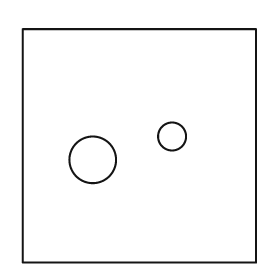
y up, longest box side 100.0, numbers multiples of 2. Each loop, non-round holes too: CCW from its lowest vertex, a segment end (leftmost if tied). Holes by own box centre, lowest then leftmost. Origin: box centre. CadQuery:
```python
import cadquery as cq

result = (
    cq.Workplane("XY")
    .moveTo(-50.0, -50.0)
    .lineTo(50.0, -50.0)
    .lineTo(50.0, 50.0)
    .lineTo(-50.0, 50.0)
    .close()
    .moveTo(-20.0, -6.0)
    .circle(10.0)
    .moveTo(14.0, 4.0)
    .circle(6.0)
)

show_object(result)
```